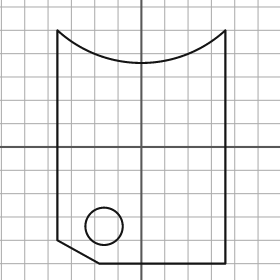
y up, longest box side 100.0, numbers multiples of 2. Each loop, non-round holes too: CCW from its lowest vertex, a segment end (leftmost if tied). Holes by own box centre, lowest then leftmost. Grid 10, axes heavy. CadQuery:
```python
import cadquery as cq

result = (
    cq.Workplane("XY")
    .moveTo(-18.0, -50.0)
    .lineTo(36.0, -50.0)
    .lineTo(36.0, 50.0)
    .threePointArc((0.0, 36.0), (-36.0, 50.0))
    .lineTo(-36.0, -40.0)
    .close()
    .moveTo(-16.0, -34.0)
    .circle(8.0)
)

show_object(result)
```